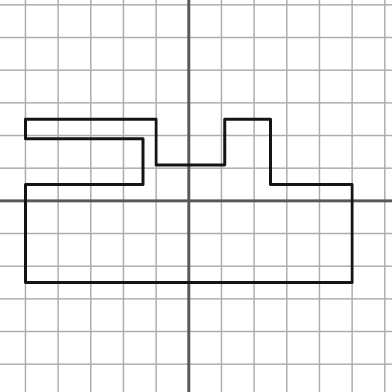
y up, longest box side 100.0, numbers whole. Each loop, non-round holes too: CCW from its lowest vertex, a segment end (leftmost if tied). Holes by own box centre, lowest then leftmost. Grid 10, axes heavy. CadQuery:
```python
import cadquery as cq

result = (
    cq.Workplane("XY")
    .moveTo(-50.0, -25.0)
    .lineTo(50.0, -25.0)
    .lineTo(50.0, 5.0)
    .lineTo(25.0, 5.0)
    .lineTo(25.0, 25.0)
    .lineTo(11.0, 25.0)
    .lineTo(11.0, 11.0)
    .lineTo(-10.0, 11.0)
    .lineTo(-10.0, 25.0)
    .lineTo(-50.0, 25.0)
    .lineTo(-50.0, 19.0)
    .lineTo(-14.0, 19.0)
    .lineTo(-14.0, 5.0)
    .lineTo(-50.0, 5.0)
    .close()
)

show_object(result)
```